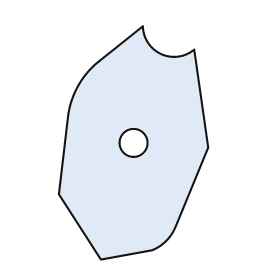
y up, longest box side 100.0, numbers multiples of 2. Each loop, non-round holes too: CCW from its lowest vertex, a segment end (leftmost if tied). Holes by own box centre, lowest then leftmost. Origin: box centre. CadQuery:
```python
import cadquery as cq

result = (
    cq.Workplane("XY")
    .moveTo(-14.0, -50.0)
    .lineTo(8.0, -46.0)
    .threePointArc((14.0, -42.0), (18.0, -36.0))
    .lineTo(32.0, -2.0)
    .lineTo(26.0, 40.0)
    .threePointArc((12.0, 38.0), (4.0, 50.0))
    .lineTo(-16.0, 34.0)
    .threePointArc((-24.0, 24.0), (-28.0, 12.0))
    .lineTo(-32.0, -22.0)
    .close()
    .moveTo(0.0, 0.0)
    .circle(6.0)
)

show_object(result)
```